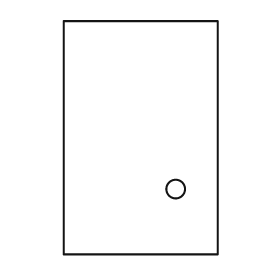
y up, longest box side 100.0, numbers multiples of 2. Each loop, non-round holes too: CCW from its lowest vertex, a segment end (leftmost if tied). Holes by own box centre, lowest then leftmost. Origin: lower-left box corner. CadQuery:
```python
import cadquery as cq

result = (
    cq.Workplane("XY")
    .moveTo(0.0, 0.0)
    .lineTo(66.0, 0.0)
    .lineTo(66.0, 100.0)
    .lineTo(0.0, 100.0)
    .close()
    .moveTo(48.0, 28.0)
    .circle(4.0)
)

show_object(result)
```